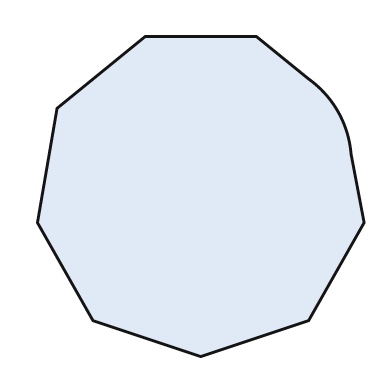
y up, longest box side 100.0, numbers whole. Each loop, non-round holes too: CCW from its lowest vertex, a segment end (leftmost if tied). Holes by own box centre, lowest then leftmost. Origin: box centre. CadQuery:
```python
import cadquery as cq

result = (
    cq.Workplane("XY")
    .moveTo(0.0, -49.0)
    .lineTo(33.0, -38.0)
    .lineTo(50.0, -8.0)
    .lineTo(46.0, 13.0)
    .threePointArc((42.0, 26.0), (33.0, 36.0))
    .lineTo(17.0, 49.0)
    .lineTo(-17.0, 49.0)
    .lineTo(-44.0, 27.0)
    .lineTo(-50.0, -8.0)
    .lineTo(-33.0, -38.0)
    .close()
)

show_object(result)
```